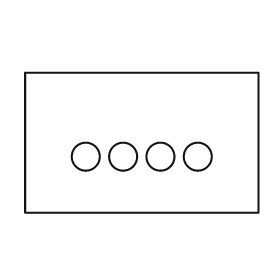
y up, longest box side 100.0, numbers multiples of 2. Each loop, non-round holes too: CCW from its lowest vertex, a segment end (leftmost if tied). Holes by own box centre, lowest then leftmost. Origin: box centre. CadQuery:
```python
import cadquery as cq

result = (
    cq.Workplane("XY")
    .moveTo(-50.0, -30.0)
    .lineTo(50.0, -30.0)
    .lineTo(50.0, 30.0)
    .lineTo(-50.0, 30.0)
    .close()
    .moveTo(-24.0, -6.0)
    .circle(6.0)
    .moveTo(-8.0, -6.0)
    .circle(6.0)
    .moveTo(8.0, -6.0)
    .circle(6.0)
    .moveTo(24.0, -6.0)
    .circle(6.0)
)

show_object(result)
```